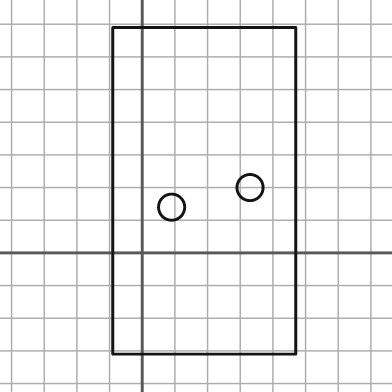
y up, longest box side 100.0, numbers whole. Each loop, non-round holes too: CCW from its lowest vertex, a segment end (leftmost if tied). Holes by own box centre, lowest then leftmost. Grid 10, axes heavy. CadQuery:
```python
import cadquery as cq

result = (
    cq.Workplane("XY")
    .moveTo(-9.0, -31.0)
    .lineTo(47.0, -31.0)
    .lineTo(47.0, 69.0)
    .lineTo(-9.0, 69.0)
    .close()
    .moveTo(9.0, 14.0)
    .circle(4.0)
    .moveTo(33.0, 20.0)
    .circle(4.0)
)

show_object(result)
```